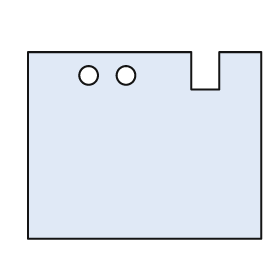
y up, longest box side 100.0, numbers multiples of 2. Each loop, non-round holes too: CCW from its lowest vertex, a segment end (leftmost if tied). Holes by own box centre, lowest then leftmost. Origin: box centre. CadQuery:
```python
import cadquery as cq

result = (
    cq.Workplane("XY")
    .moveTo(-50.0, -40.0)
    .lineTo(50.0, -40.0)
    .lineTo(50.0, 40.0)
    .lineTo(32.0, 40.0)
    .lineTo(32.0, 24.0)
    .lineTo(20.0, 24.0)
    .lineTo(20.0, 40.0)
    .lineTo(-50.0, 40.0)
    .close()
    .moveTo(-24.0, 30.0)
    .circle(4.0)
    .moveTo(-8.0, 30.0)
    .circle(4.0)
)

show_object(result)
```